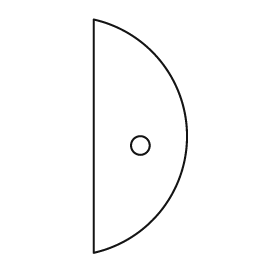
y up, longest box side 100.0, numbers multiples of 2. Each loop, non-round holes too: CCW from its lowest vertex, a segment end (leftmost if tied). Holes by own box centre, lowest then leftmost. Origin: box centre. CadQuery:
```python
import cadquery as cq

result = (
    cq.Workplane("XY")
    .moveTo(-20.0, -50.0)
    .threePointArc((20.0, 0.0), (-20.0, 50.0))
    .close()
    .moveTo(0.0, -4.0)
    .circle(4.0)
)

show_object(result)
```